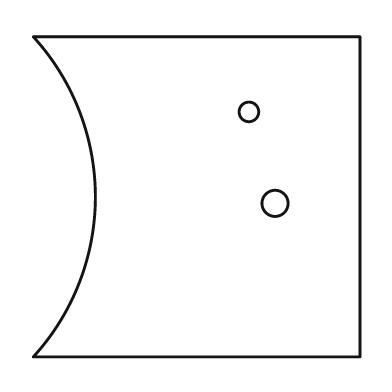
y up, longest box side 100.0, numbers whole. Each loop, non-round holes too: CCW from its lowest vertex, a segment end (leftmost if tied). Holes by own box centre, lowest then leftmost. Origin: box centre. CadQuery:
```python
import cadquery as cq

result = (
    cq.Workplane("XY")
    .moveTo(-50.0, -49.0)
    .lineTo(50.0, -49.0)
    .lineTo(50.0, 49.0)
    .lineTo(-50.0, 49.0)
    .threePointArc((-31.0, 0.0), (-50.0, -49.0))
    .close()
    .moveTo(24.0, -2.0)
    .circle(4.0)
    .moveTo(16.0, 26.0)
    .circle(3.0)
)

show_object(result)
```